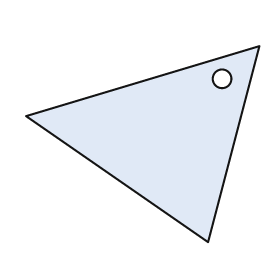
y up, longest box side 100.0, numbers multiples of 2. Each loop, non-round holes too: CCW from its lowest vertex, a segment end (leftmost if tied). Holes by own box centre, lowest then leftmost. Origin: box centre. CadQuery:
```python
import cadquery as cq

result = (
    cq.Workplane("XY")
    .moveTo(28.0, -42.0)
    .lineTo(50.0, 42.0)
    .lineTo(-50.0, 12.0)
    .close()
    .moveTo(34.0, 28.0)
    .circle(4.0)
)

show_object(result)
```